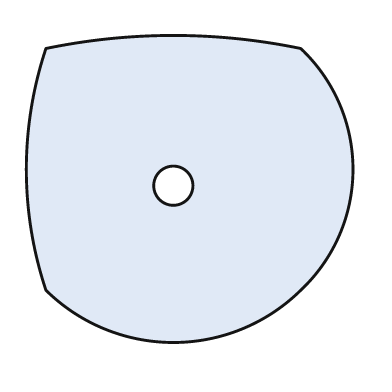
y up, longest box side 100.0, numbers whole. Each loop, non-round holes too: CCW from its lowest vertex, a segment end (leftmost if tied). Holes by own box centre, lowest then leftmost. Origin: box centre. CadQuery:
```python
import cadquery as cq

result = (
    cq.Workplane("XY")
    .moveTo(-44.0, -31.0)
    .threePointArc((-5.0, -47.0), (34.0, -31.0))
    .threePointArc((50.0, 6.0), (34.0, 43.0))
    .threePointArc((-5.0, 47.0), (-44.0, 43.0))
    .threePointArc((-50.0, 6.0), (-44.0, -31.0))
    .close()
    .moveTo(-5.0, 1.0)
    .circle(6.0)
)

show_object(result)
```